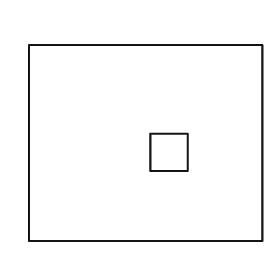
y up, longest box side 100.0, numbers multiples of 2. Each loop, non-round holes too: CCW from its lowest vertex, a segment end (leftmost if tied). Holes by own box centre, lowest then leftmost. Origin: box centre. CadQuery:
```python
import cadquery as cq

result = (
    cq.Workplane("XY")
    .moveTo(-50.0, -42.0)
    .lineTo(50.0, -42.0)
    .lineTo(50.0, 42.0)
    .lineTo(-50.0, 42.0)
    .close()
    .moveTo(2.0, -12.0)
    .lineTo(18.0, -12.0)
    .lineTo(18.0, 4.0)
    .lineTo(2.0, 4.0)
    .close()
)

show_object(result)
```